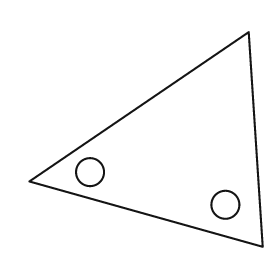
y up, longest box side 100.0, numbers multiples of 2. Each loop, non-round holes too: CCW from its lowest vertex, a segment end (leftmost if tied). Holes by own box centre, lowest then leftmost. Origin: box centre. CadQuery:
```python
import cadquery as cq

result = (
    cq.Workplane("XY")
    .moveTo(50.0, -46.0)
    .lineTo(44.0, 46.0)
    .lineTo(-50.0, -18.0)
    .close()
    .moveTo(34.0, -28.0)
    .circle(6.0)
    .moveTo(-24.0, -14.0)
    .circle(6.0)
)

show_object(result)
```